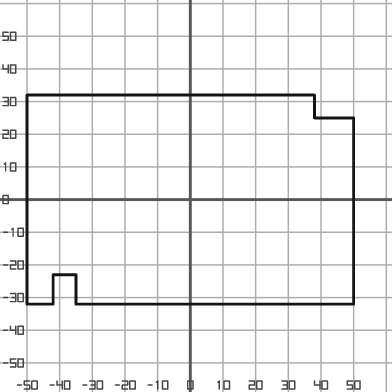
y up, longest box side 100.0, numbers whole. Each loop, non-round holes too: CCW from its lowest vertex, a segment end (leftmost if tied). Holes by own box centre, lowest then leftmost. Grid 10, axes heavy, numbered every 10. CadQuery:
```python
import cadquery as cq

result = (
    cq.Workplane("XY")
    .moveTo(-50.0, -32.0)
    .lineTo(-42.0, -32.0)
    .lineTo(-42.0, -23.0)
    .lineTo(-35.0, -23.0)
    .lineTo(-35.0, -32.0)
    .lineTo(50.0, -32.0)
    .lineTo(50.0, 25.0)
    .lineTo(38.0, 25.0)
    .lineTo(38.0, 32.0)
    .lineTo(-50.0, 32.0)
    .close()
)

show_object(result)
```